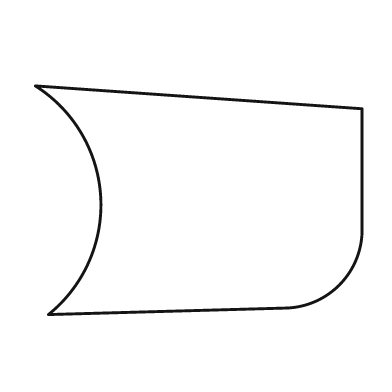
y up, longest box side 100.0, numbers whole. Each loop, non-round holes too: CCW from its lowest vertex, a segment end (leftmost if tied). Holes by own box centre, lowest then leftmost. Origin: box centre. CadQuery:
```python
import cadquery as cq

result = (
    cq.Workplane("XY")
    .moveTo(-46.0, -35.0)
    .lineTo(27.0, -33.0)
    .threePointArc((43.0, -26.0), (50.0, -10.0))
    .lineTo(50.0, 28.0)
    .lineTo(-50.0, 35.0)
    .threePointArc((-30.0, 1.0), (-46.0, -35.0))
    .close()
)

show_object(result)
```